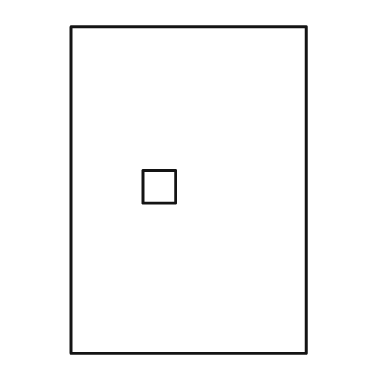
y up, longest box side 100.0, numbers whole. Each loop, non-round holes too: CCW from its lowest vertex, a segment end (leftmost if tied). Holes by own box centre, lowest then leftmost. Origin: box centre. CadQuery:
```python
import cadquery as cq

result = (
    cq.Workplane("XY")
    .moveTo(-36.0, -50.0)
    .lineTo(36.0, -50.0)
    .lineTo(36.0, 50.0)
    .lineTo(-36.0, 50.0)
    .close()
    .moveTo(-14.0, -4.0)
    .lineTo(-4.0, -4.0)
    .lineTo(-4.0, 6.0)
    .lineTo(-14.0, 6.0)
    .close()
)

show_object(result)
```